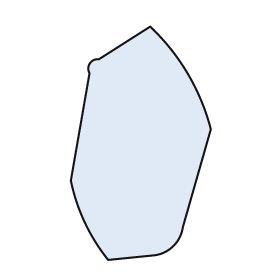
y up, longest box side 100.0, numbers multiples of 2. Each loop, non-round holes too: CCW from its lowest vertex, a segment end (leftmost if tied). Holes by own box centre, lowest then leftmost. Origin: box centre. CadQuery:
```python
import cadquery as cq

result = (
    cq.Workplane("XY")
    .moveTo(-14.0, -50.0)
    .lineTo(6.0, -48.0)
    .threePointArc((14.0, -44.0), (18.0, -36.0))
    .lineTo(30.0, 6.0)
    .threePointArc((20.0, 30.0), (4.0, 50.0))
    .lineTo(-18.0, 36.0)
    .threePointArc((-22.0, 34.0), (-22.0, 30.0))
    .lineTo(-30.0, -16.0)
    .threePointArc((-24.0, -34.0), (-14.0, -50.0))
    .close()
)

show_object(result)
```